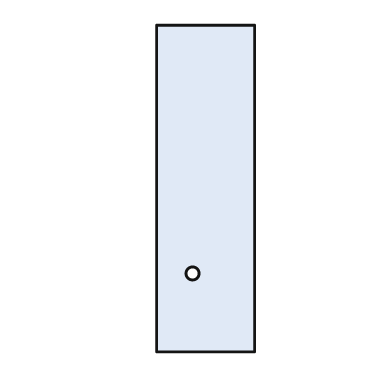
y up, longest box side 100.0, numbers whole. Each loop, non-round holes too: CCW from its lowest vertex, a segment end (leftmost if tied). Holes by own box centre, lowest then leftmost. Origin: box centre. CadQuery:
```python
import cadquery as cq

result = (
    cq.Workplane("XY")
    .moveTo(-15.0, -50.0)
    .lineTo(15.0, -50.0)
    .lineTo(15.0, 50.0)
    .lineTo(-15.0, 50.0)
    .close()
    .moveTo(-4.0, -26.0)
    .circle(2.0)
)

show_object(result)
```